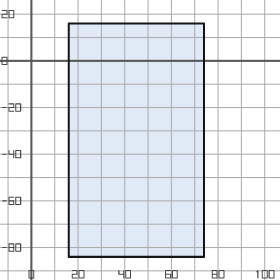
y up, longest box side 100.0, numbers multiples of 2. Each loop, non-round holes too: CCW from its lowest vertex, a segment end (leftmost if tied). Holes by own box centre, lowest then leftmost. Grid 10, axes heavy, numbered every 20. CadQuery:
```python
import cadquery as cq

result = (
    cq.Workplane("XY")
    .moveTo(16.0, -84.0)
    .lineTo(74.0, -84.0)
    .lineTo(74.0, 16.0)
    .lineTo(16.0, 16.0)
    .close()
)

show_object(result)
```